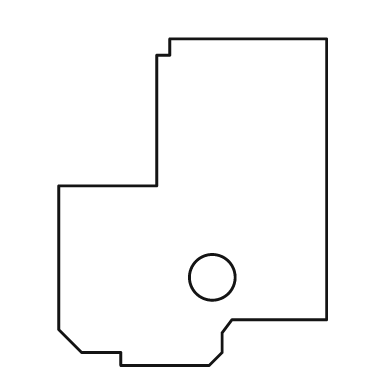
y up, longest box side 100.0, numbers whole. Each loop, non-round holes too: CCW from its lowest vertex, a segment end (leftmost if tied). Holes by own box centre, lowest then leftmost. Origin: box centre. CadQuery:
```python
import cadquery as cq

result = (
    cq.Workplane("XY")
    .moveTo(-22.0, -50.0)
    .lineTo(5.0, -50.0)
    .lineTo(9.0, -46.0)
    .lineTo(9.0, -40.0)
    .lineTo(12.0, -36.0)
    .lineTo(41.0, -36.0)
    .lineTo(41.0, 50.0)
    .lineTo(-7.0, 50.0)
    .lineTo(-7.0, 45.0)
    .lineTo(-11.0, 45.0)
    .lineTo(-11.0, 5.0)
    .lineTo(-41.0, 5.0)
    .lineTo(-41.0, -39.0)
    .lineTo(-34.0, -46.0)
    .lineTo(-22.0, -46.0)
    .close()
    .moveTo(6.0, -23.0)
    .circle(7.0)
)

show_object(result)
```